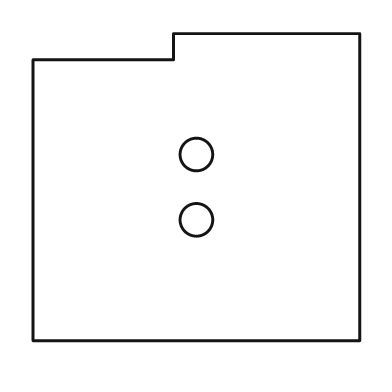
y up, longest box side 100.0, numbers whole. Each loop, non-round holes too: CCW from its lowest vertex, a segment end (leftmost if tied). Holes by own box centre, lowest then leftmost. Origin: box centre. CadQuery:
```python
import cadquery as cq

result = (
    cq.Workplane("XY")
    .moveTo(-50.0, -47.0)
    .lineTo(50.0, -47.0)
    .lineTo(50.0, 47.0)
    .lineTo(-7.0, 47.0)
    .lineTo(-7.0, 39.0)
    .lineTo(-50.0, 39.0)
    .close()
    .moveTo(0.0, -10.0)
    .circle(5.0)
    .moveTo(0.0, 10.0)
    .circle(5.0)
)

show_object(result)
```